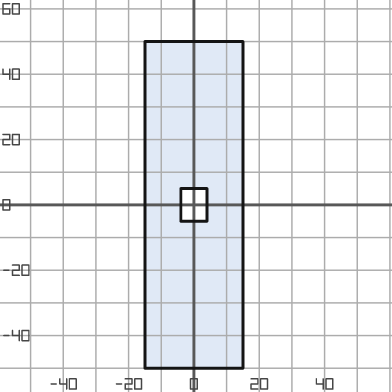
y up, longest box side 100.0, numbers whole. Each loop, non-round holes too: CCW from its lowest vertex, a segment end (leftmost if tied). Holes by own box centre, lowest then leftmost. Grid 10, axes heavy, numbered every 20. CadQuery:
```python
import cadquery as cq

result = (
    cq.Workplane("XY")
    .moveTo(-15.0, -50.0)
    .lineTo(15.0, -50.0)
    .lineTo(15.0, 50.0)
    .lineTo(-15.0, 50.0)
    .close()
    .moveTo(-4.0, -5.0)
    .lineTo(4.0, -5.0)
    .lineTo(4.0, 5.0)
    .lineTo(-4.0, 5.0)
    .close()
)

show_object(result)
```